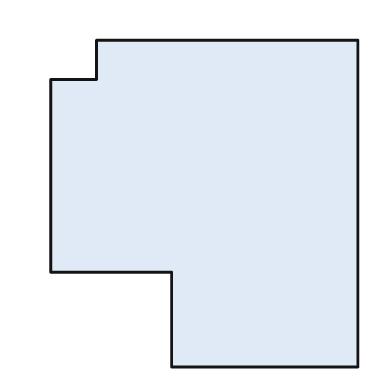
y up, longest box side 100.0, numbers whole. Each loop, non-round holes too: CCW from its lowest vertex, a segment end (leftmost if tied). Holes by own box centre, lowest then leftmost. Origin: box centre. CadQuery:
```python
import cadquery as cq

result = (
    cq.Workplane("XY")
    .moveTo(-10.0, -50.0)
    .lineTo(47.0, -50.0)
    .lineTo(47.0, 50.0)
    .lineTo(-33.0, 50.0)
    .lineTo(-33.0, 38.0)
    .lineTo(-47.0, 38.0)
    .lineTo(-47.0, -21.0)
    .lineTo(-10.0, -21.0)
    .close()
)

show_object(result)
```